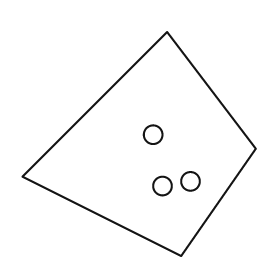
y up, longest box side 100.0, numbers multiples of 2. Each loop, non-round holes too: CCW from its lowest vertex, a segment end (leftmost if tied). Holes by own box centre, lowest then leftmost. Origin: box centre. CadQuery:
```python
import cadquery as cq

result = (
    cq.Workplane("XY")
    .moveTo(18.0, -48.0)
    .lineTo(50.0, -2.0)
    .lineTo(12.0, 48.0)
    .lineTo(-50.0, -14.0)
    .close()
    .moveTo(10.0, -18.0)
    .circle(4.0)
    .moveTo(22.0, -16.0)
    .circle(4.0)
    .moveTo(6.0, 4.0)
    .circle(4.0)
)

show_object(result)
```